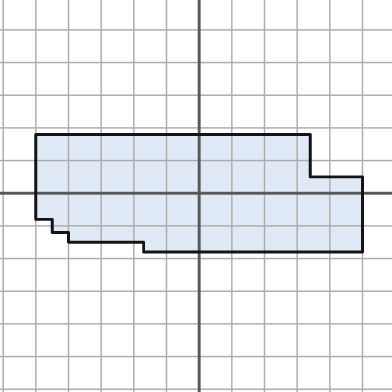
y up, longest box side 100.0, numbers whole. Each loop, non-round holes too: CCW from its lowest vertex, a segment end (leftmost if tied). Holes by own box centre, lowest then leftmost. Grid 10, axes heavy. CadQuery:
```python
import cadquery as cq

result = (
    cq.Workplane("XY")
    .moveTo(-17.0, -18.0)
    .lineTo(50.0, -18.0)
    .lineTo(50.0, 5.0)
    .lineTo(34.0, 5.0)
    .lineTo(34.0, 18.0)
    .lineTo(-50.0, 18.0)
    .lineTo(-50.0, -8.0)
    .lineTo(-45.0, -8.0)
    .lineTo(-45.0, -12.0)
    .lineTo(-40.0, -12.0)
    .lineTo(-40.0, -15.0)
    .lineTo(-17.0, -15.0)
    .close()
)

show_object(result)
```